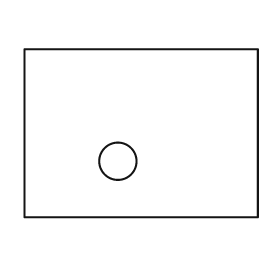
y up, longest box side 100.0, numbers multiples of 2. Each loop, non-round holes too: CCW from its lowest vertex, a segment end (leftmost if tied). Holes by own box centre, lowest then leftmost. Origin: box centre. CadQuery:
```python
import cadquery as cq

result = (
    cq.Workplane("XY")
    .moveTo(-50.0, -36.0)
    .lineTo(50.0, -36.0)
    .lineTo(50.0, 36.0)
    .lineTo(-50.0, 36.0)
    .close()
    .moveTo(-10.0, -12.0)
    .circle(8.0)
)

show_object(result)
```